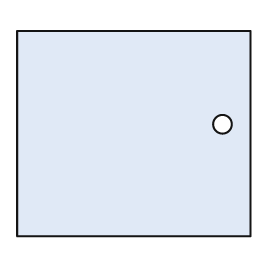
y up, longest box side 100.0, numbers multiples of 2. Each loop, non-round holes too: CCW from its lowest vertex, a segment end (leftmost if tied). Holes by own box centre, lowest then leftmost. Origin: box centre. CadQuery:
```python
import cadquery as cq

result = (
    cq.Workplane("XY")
    .moveTo(-50.0, -44.0)
    .lineTo(50.0, -44.0)
    .lineTo(50.0, 44.0)
    .lineTo(-50.0, 44.0)
    .close()
    .moveTo(38.0, 4.0)
    .circle(4.0)
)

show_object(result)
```